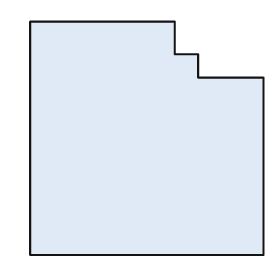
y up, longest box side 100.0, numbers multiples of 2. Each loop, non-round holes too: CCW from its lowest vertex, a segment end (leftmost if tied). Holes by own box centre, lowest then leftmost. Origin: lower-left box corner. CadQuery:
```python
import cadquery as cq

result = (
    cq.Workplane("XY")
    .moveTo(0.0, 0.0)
    .lineTo(100.0, 0.0)
    .lineTo(100.0, 76.0)
    .lineTo(72.0, 76.0)
    .lineTo(72.0, 86.0)
    .lineTo(62.0, 86.0)
    .lineTo(62.0, 100.0)
    .lineTo(0.0, 100.0)
    .close()
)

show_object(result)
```